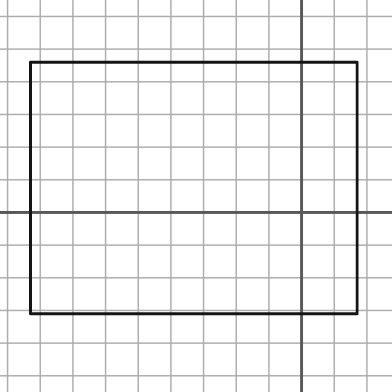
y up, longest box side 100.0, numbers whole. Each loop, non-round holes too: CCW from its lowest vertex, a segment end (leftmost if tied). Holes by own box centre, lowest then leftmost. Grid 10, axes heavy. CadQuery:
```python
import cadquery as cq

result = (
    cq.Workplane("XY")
    .moveTo(-83.0, -31.0)
    .lineTo(17.0, -31.0)
    .lineTo(17.0, 46.0)
    .lineTo(-83.0, 46.0)
    .close()
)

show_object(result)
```